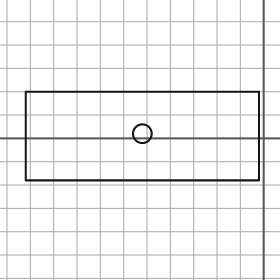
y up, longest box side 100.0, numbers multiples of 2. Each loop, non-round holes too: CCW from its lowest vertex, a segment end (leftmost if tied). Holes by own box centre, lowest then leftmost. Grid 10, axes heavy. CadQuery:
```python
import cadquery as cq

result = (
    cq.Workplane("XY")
    .moveTo(-102.0, -18.0)
    .lineTo(-2.0, -18.0)
    .lineTo(-2.0, 20.0)
    .lineTo(-102.0, 20.0)
    .close()
    .moveTo(-52.0, 2.0)
    .circle(4.0)
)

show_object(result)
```